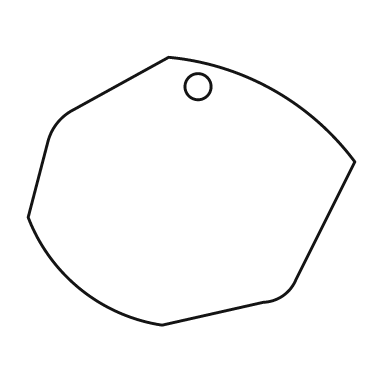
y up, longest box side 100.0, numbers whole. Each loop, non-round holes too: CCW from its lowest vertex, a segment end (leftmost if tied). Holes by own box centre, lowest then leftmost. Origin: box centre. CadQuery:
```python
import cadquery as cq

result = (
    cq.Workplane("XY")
    .moveTo(-9.0, -41.0)
    .lineTo(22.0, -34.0)
    .threePointArc((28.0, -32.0), (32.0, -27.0))
    .lineTo(50.0, 9.0)
    .threePointArc((25.0, 31.0), (-7.0, 41.0))
    .lineTo(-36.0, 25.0)
    .threePointArc((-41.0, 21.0), (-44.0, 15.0))
    .lineTo(-50.0, -8.0)
    .threePointArc((-34.0, -30.0), (-9.0, -41.0))
    .close()
    .moveTo(2.0, 32.0)
    .circle(4.0)
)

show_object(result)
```